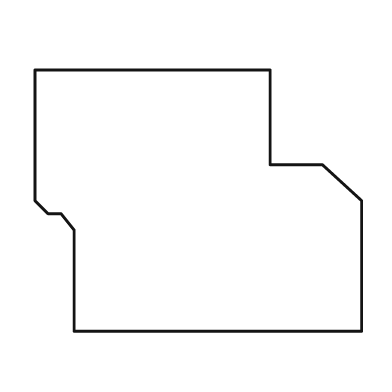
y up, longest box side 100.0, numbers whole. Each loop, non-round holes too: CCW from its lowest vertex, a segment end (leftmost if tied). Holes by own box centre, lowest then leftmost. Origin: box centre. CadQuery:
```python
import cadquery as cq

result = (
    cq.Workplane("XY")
    .moveTo(-38.0, -40.0)
    .lineTo(50.0, -40.0)
    .lineTo(50.0, 0.0)
    .lineTo(38.0, 11.0)
    .lineTo(22.0, 11.0)
    .lineTo(22.0, 40.0)
    .lineTo(-50.0, 40.0)
    .lineTo(-50.0, 0.0)
    .lineTo(-46.0, -4.0)
    .lineTo(-42.0, -4.0)
    .lineTo(-38.0, -9.0)
    .close()
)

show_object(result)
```